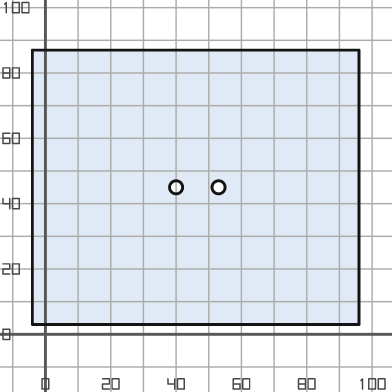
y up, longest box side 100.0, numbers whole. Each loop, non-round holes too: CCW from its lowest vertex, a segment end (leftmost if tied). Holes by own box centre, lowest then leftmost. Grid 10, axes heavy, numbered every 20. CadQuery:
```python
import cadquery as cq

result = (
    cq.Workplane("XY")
    .moveTo(-4.0, 3.0)
    .lineTo(96.0, 3.0)
    .lineTo(96.0, 87.0)
    .lineTo(-4.0, 87.0)
    .close()
    .moveTo(40.0, 45.0)
    .circle(2.0)
    .moveTo(53.0, 45.0)
    .circle(2.0)
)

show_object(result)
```